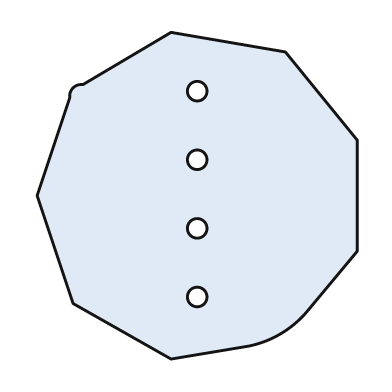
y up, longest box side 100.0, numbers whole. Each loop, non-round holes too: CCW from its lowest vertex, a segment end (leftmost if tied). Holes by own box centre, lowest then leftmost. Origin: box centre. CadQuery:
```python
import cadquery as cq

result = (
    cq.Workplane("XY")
    .moveTo(-8.0, -50.0)
    .lineTo(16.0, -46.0)
    .threePointArc((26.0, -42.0), (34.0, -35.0))
    .lineTo(49.0, -17.0)
    .lineTo(49.0, 17.0)
    .lineTo(27.0, 44.0)
    .lineTo(-8.0, 50.0)
    .lineTo(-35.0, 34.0)
    .threePointArc((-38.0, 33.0), (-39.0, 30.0))
    .lineTo(-49.0, 0.0)
    .lineTo(-38.0, -33.0)
    .close()
    .moveTo(0.0, -31.0)
    .circle(3.0)
    .moveTo(0.0, -10.0)
    .circle(3.0)
    .moveTo(0.0, 11.0)
    .circle(3.0)
    .moveTo(0.0, 32.0)
    .circle(3.0)
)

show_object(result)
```